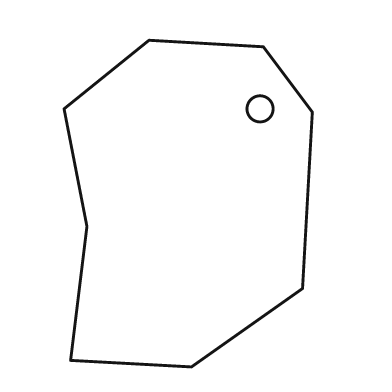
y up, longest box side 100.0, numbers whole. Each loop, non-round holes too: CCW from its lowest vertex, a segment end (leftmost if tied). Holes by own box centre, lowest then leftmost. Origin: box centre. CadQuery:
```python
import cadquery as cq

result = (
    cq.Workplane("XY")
    .moveTo(1.0, -50.0)
    .lineTo(35.0, -26.0)
    .lineTo(38.0, 28.0)
    .lineTo(23.0, 48.0)
    .lineTo(-12.0, 50.0)
    .lineTo(-38.0, 29.0)
    .lineTo(-31.0, -7.0)
    .lineTo(-36.0, -48.0)
    .close()
    .moveTo(22.0, 29.0)
    .circle(4.0)
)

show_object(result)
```